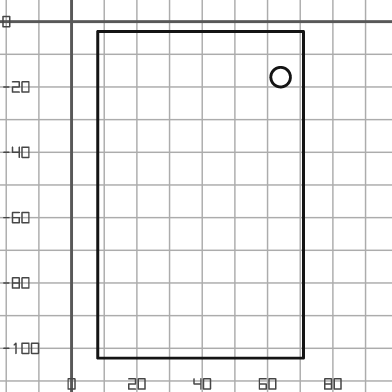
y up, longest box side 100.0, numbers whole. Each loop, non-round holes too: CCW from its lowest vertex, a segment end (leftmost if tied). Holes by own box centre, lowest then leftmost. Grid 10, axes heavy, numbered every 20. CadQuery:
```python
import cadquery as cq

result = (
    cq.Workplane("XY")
    .moveTo(8.0, -103.0)
    .lineTo(71.0, -103.0)
    .lineTo(71.0, -3.0)
    .lineTo(8.0, -3.0)
    .close()
    .moveTo(64.0, -17.0)
    .circle(3.0)
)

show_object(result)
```